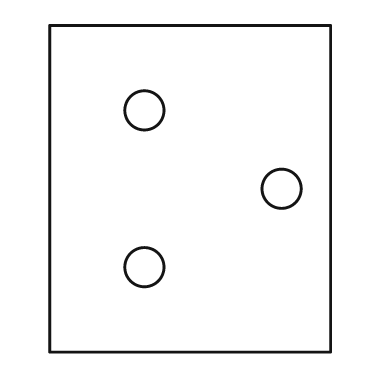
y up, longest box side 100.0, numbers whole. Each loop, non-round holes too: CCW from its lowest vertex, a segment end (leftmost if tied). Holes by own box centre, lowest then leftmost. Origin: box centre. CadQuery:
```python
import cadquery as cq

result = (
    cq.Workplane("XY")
    .moveTo(-43.0, -50.0)
    .lineTo(43.0, -50.0)
    .lineTo(43.0, 50.0)
    .lineTo(-43.0, 50.0)
    .close()
    .moveTo(-14.0, -24.0)
    .circle(6.0)
    .moveTo(28.0, 0.0)
    .circle(6.0)
    .moveTo(-14.0, 24.0)
    .circle(6.0)
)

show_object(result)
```